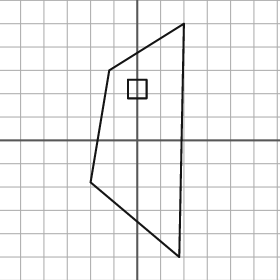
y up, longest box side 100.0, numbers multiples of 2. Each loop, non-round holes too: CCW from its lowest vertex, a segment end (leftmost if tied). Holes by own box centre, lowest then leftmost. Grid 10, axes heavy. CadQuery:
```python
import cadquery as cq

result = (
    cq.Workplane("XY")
    .moveTo(18.0, -50.0)
    .lineTo(20.0, 50.0)
    .lineTo(-12.0, 30.0)
    .lineTo(-20.0, -18.0)
    .close()
    .moveTo(-4.0, 18.0)
    .lineTo(4.0, 18.0)
    .lineTo(4.0, 26.0)
    .lineTo(-4.0, 26.0)
    .close()
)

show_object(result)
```